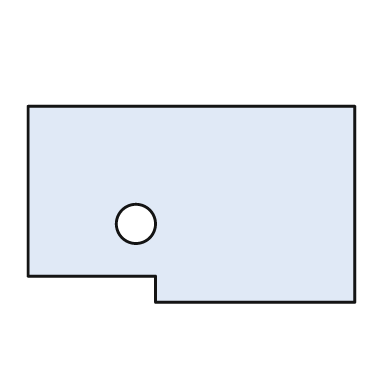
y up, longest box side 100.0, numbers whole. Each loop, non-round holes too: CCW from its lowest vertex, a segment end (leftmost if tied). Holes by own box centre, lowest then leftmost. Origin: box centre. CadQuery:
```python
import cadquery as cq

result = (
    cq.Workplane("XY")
    .moveTo(-11.0, -30.0)
    .lineTo(50.0, -30.0)
    .lineTo(50.0, 30.0)
    .lineTo(-50.0, 30.0)
    .lineTo(-50.0, -22.0)
    .lineTo(-11.0, -22.0)
    .close()
    .moveTo(-17.0, -6.0)
    .circle(6.0)
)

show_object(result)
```